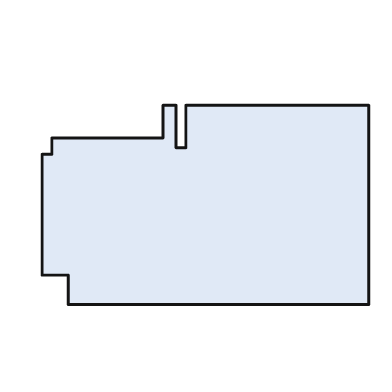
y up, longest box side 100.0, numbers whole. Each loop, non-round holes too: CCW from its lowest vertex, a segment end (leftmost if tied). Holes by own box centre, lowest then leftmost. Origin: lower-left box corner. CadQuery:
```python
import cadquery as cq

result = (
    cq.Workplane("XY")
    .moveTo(8.0, 0.0)
    .lineTo(100.0, 0.0)
    .lineTo(100.0, 61.0)
    .lineTo(44.0, 61.0)
    .lineTo(44.0, 48.0)
    .lineTo(41.0, 48.0)
    .lineTo(41.0, 61.0)
    .lineTo(37.0, 61.0)
    .lineTo(37.0, 51.0)
    .lineTo(3.0, 51.0)
    .lineTo(3.0, 46.0)
    .lineTo(0.0, 46.0)
    .lineTo(0.0, 9.0)
    .lineTo(8.0, 9.0)
    .close()
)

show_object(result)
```